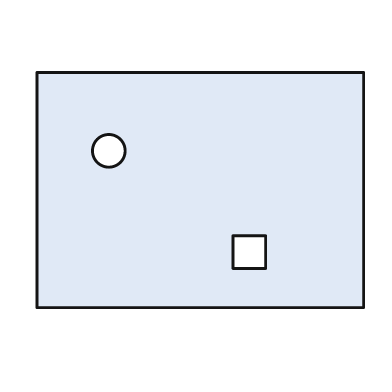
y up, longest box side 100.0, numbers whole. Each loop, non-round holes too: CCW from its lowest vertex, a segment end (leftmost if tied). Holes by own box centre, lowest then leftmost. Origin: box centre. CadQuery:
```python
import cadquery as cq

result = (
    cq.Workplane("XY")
    .moveTo(-50.0, -36.0)
    .lineTo(50.0, -36.0)
    .lineTo(50.0, 36.0)
    .lineTo(-50.0, 36.0)
    .close()
    .moveTo(10.0, -24.0)
    .lineTo(20.0, -24.0)
    .lineTo(20.0, -14.0)
    .lineTo(10.0, -14.0)
    .close()
    .moveTo(-28.0, 12.0)
    .circle(5.0)
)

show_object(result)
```